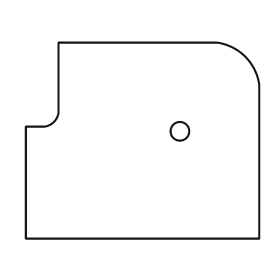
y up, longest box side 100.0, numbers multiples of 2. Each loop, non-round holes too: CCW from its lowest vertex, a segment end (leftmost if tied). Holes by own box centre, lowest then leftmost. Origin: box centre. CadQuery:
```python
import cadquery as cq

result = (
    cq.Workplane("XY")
    .moveTo(-50.0, -42.0)
    .lineTo(50.0, -42.0)
    .lineTo(50.0, 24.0)
    .threePointArc((44.0, 36.0), (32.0, 42.0))
    .lineTo(-36.0, 42.0)
    .lineTo(-36.0, 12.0)
    .threePointArc((-38.0, 8.0), (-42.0, 6.0))
    .lineTo(-50.0, 6.0)
    .close()
    .moveTo(16.0, 4.0)
    .circle(4.0)
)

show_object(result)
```